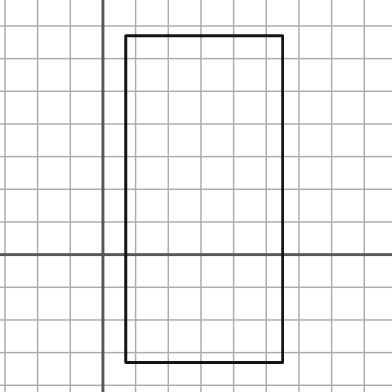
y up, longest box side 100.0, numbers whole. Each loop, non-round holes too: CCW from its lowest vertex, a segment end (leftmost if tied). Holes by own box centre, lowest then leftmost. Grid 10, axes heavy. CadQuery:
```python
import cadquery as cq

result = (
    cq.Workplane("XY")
    .moveTo(7.0, -33.0)
    .lineTo(55.0, -33.0)
    .lineTo(55.0, 67.0)
    .lineTo(7.0, 67.0)
    .close()
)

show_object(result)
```